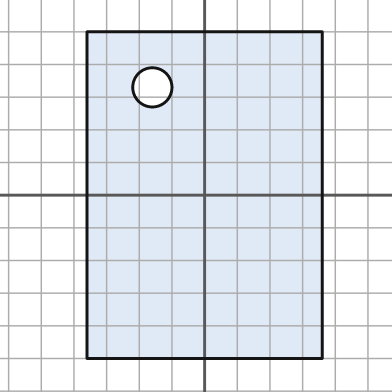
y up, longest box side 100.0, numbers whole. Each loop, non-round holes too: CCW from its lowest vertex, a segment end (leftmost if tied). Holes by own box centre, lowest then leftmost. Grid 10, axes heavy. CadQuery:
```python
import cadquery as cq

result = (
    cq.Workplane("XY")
    .moveTo(-36.0, -50.0)
    .lineTo(36.0, -50.0)
    .lineTo(36.0, 50.0)
    .lineTo(-36.0, 50.0)
    .close()
    .moveTo(-16.0, 33.0)
    .circle(6.0)
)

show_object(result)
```